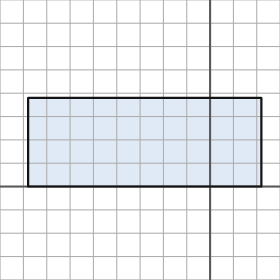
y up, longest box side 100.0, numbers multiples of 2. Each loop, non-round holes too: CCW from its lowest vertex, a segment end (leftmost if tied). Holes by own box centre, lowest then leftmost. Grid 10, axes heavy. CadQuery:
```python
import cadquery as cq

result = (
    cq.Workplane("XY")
    .moveTo(-78.0, 0.0)
    .lineTo(22.0, 0.0)
    .lineTo(22.0, 38.0)
    .lineTo(-78.0, 38.0)
    .close()
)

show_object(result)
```